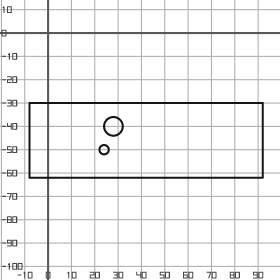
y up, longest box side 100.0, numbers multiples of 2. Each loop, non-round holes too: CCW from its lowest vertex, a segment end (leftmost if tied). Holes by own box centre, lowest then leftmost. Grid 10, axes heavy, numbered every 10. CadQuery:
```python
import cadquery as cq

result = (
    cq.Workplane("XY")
    .moveTo(-8.0, -62.0)
    .lineTo(92.0, -62.0)
    .lineTo(92.0, -30.0)
    .lineTo(-8.0, -30.0)
    .close()
    .moveTo(24.0, -50.0)
    .circle(2.0)
    .moveTo(28.0, -40.0)
    .circle(4.0)
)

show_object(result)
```